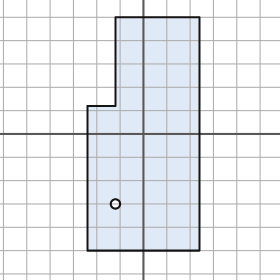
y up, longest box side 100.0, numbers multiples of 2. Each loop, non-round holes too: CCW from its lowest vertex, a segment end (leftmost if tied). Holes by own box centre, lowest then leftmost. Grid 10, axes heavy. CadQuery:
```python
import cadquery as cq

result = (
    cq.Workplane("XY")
    .moveTo(-24.0, -50.0)
    .lineTo(24.0, -50.0)
    .lineTo(24.0, 50.0)
    .lineTo(-12.0, 50.0)
    .lineTo(-12.0, 12.0)
    .lineTo(-24.0, 12.0)
    .close()
    .moveTo(-12.0, -30.0)
    .circle(2.0)
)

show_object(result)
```